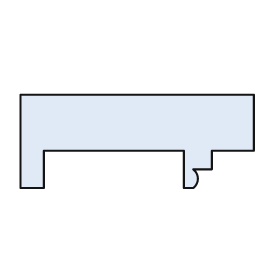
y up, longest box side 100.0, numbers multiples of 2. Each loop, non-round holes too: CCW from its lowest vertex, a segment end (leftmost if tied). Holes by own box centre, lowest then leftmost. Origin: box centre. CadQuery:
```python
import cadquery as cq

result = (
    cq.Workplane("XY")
    .moveTo(-50.0, -20.0)
    .lineTo(-40.0, -20.0)
    .lineTo(-40.0, -4.0)
    .lineTo(20.0, -4.0)
    .lineTo(20.0, -20.0)
    .lineTo(24.0, -20.0)
    .threePointArc((26.0, -16.0), (24.0, -12.0))
    .lineTo(32.0, -12.0)
    .lineTo(32.0, -4.0)
    .lineTo(50.0, -4.0)
    .lineTo(50.0, 20.0)
    .lineTo(-50.0, 20.0)
    .close()
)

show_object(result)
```